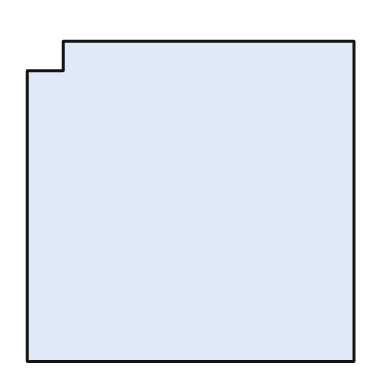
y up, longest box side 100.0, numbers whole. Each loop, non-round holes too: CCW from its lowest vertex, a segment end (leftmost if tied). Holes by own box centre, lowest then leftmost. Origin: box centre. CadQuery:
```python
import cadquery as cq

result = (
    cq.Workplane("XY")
    .moveTo(-50.0, -49.0)
    .lineTo(50.0, -49.0)
    .lineTo(50.0, 49.0)
    .lineTo(-39.0, 49.0)
    .lineTo(-39.0, 40.0)
    .lineTo(-50.0, 40.0)
    .close()
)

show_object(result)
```